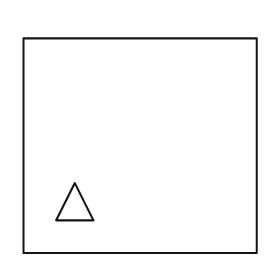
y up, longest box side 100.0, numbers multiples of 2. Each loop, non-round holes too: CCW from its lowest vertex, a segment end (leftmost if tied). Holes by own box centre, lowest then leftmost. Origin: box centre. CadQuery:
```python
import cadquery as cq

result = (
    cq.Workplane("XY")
    .moveTo(-50.0, -46.0)
    .lineTo(50.0, -46.0)
    .lineTo(50.0, 46.0)
    .lineTo(-50.0, 46.0)
    .close()
    .moveTo(-36.0, -32.0)
    .lineTo(-20.0, -32.0)
    .lineTo(-28.0, -16.0)
    .close()
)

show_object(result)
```